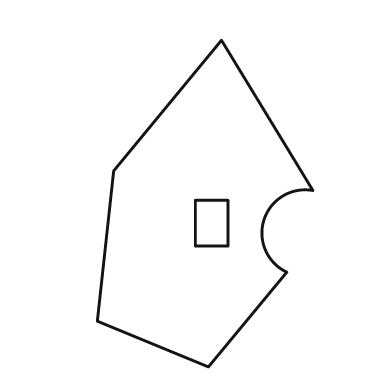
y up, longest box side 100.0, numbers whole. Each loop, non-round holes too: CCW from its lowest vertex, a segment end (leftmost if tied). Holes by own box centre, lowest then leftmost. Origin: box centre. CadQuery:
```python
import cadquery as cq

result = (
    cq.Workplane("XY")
    .moveTo(1.0, -50.0)
    .lineTo(25.0, -21.0)
    .threePointArc((18.0, -5.0), (33.0, 4.0))
    .lineTo(5.0, 50.0)
    .lineTo(-28.0, 10.0)
    .lineTo(-33.0, -36.0)
    .close()
    .moveTo(-3.0, -13.0)
    .lineTo(7.0, -13.0)
    .lineTo(7.0, 1.0)
    .lineTo(-3.0, 1.0)
    .close()
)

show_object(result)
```